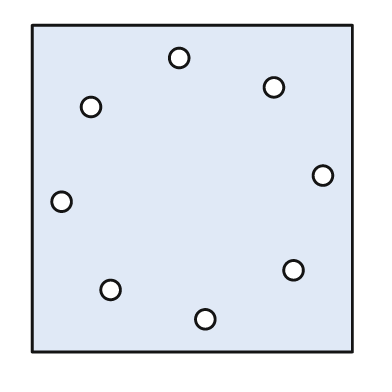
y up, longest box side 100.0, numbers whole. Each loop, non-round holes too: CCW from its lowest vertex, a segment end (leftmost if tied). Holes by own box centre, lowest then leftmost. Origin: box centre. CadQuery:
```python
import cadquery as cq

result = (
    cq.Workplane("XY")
    .moveTo(-49.0, -50.0)
    .lineTo(49.0, -50.0)
    .lineTo(49.0, 50.0)
    .lineTo(-49.0, 50.0)
    .close()
    .moveTo(4.0, -40.0)
    .circle(3.0)
    .moveTo(-25.0, -31.0)
    .circle(3.0)
    .moveTo(31.0, -25.0)
    .circle(3.0)
    .moveTo(-40.0, -4.0)
    .circle(3.0)
    .moveTo(40.0, 4.0)
    .circle(3.0)
    .moveTo(-31.0, 25.0)
    .circle(3.0)
    .moveTo(25.0, 31.0)
    .circle(3.0)
    .moveTo(-4.0, 40.0)
    .circle(3.0)
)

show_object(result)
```